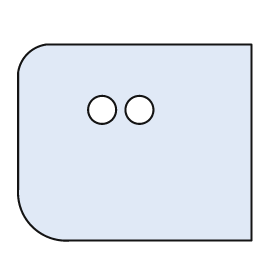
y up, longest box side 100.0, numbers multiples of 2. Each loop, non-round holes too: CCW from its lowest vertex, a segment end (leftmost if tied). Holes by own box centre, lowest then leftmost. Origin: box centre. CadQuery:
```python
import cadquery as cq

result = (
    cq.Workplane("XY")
    .moveTo(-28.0, -42.0)
    .lineTo(50.0, -42.0)
    .lineTo(50.0, 42.0)
    .lineTo(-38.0, 42.0)
    .threePointArc((-46.0, 38.0), (-50.0, 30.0))
    .lineTo(-50.0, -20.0)
    .threePointArc((-44.0, -36.0), (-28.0, -42.0))
    .close()
    .moveTo(-14.0, 14.0)
    .circle(6.0)
    .moveTo(2.0, 14.0)
    .circle(6.0)
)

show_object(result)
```